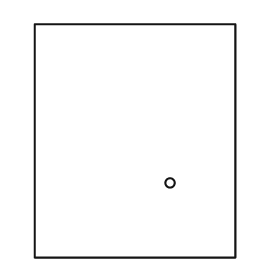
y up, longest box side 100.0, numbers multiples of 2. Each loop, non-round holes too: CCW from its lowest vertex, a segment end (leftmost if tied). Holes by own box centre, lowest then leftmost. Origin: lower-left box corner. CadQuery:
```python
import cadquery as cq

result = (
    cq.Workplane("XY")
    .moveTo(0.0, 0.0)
    .lineTo(86.0, 0.0)
    .lineTo(86.0, 100.0)
    .lineTo(0.0, 100.0)
    .close()
    .moveTo(58.0, 32.0)
    .circle(2.0)
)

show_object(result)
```